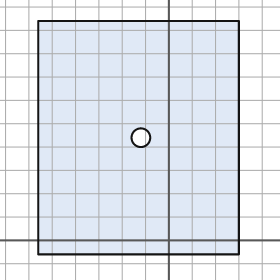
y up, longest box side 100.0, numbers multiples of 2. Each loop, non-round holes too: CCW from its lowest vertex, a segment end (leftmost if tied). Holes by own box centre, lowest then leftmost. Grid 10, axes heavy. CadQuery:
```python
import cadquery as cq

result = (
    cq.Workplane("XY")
    .moveTo(-56.0, -6.0)
    .lineTo(30.0, -6.0)
    .lineTo(30.0, 94.0)
    .lineTo(-56.0, 94.0)
    .close()
    .moveTo(-12.0, 44.0)
    .circle(4.0)
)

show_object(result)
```